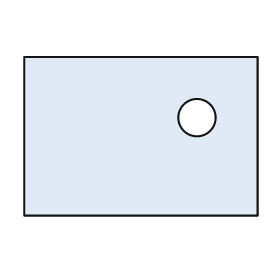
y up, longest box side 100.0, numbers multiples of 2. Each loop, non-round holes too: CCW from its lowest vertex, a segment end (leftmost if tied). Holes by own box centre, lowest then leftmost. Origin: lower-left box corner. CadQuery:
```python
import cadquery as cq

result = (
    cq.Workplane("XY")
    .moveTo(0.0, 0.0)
    .lineTo(100.0, 0.0)
    .lineTo(100.0, 68.0)
    .lineTo(0.0, 68.0)
    .close()
    .moveTo(74.0, 42.0)
    .circle(8.0)
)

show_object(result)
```